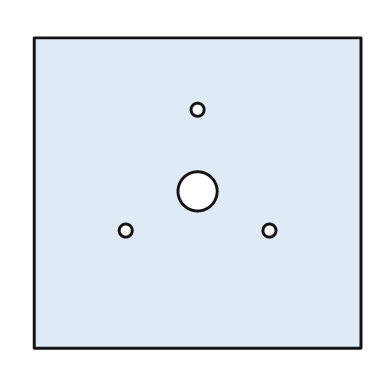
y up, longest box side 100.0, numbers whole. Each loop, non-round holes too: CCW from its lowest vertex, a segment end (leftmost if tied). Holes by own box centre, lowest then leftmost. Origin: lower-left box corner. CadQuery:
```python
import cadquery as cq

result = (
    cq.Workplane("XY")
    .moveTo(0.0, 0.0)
    .lineTo(100.0, 0.0)
    .lineTo(100.0, 95.0)
    .lineTo(0.0, 95.0)
    .close()
    .moveTo(28.0, 36.0)
    .circle(2.0)
    .moveTo(72.0, 36.0)
    .circle(2.0)
    .moveTo(50.0, 48.0)
    .circle(6.0)
    .moveTo(50.0, 73.0)
    .circle(2.0)
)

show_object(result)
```